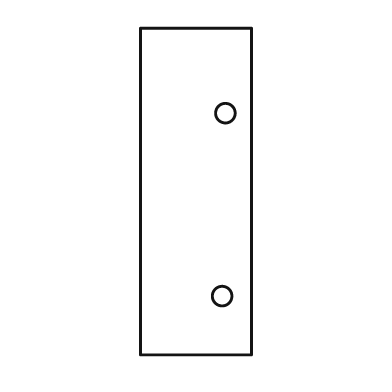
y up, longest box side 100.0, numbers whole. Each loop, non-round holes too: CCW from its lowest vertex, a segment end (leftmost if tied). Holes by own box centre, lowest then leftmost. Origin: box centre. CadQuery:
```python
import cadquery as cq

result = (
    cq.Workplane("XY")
    .moveTo(-17.0, -50.0)
    .lineTo(17.0, -50.0)
    .lineTo(17.0, 50.0)
    .lineTo(-17.0, 50.0)
    .close()
    .moveTo(8.0, -32.0)
    .circle(3.0)
    .moveTo(9.0, 24.0)
    .circle(3.0)
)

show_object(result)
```